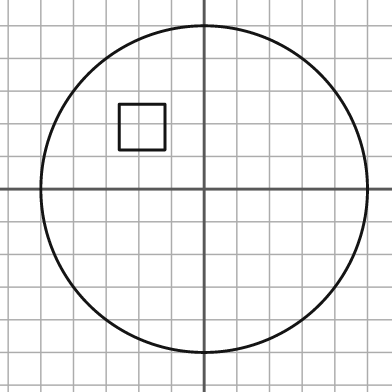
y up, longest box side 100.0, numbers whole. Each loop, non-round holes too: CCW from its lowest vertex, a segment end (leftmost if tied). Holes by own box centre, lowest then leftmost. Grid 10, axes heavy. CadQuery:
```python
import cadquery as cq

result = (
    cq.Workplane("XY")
    .moveTo(0.0, 0.0)
    .circle(50.0)
    .moveTo(-26.0, 12.0)
    .lineTo(-12.0, 12.0)
    .lineTo(-12.0, 26.0)
    .lineTo(-26.0, 26.0)
    .close()
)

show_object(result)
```